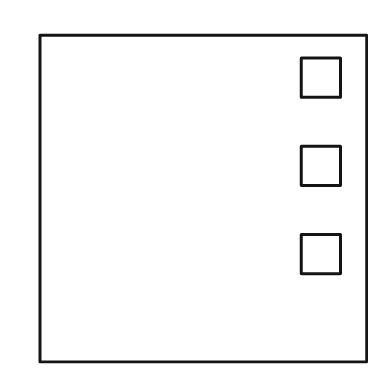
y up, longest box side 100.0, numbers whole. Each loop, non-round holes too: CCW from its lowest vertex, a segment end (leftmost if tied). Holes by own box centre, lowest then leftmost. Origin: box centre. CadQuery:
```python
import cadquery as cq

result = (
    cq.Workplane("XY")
    .moveTo(-50.0, -50.0)
    .lineTo(50.0, -50.0)
    .lineTo(50.0, 50.0)
    .lineTo(-50.0, 50.0)
    .close()
    .moveTo(30.0, -23.0)
    .lineTo(42.0, -23.0)
    .lineTo(42.0, -11.0)
    .lineTo(30.0, -11.0)
    .close()
    .moveTo(30.0, 4.0)
    .lineTo(42.0, 4.0)
    .lineTo(42.0, 16.0)
    .lineTo(30.0, 16.0)
    .close()
    .moveTo(30.0, 31.0)
    .lineTo(42.0, 31.0)
    .lineTo(42.0, 43.0)
    .lineTo(30.0, 43.0)
    .close()
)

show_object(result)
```